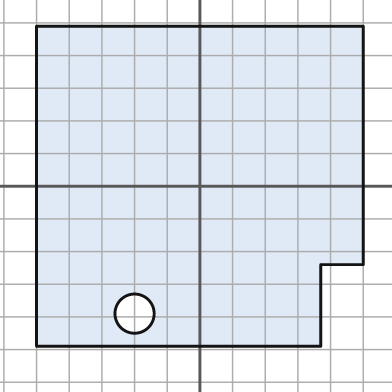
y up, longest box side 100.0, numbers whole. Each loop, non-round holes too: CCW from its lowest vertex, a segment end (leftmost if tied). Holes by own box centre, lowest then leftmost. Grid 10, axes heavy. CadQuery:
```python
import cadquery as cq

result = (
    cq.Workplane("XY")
    .moveTo(-50.0, -49.0)
    .lineTo(37.0, -49.0)
    .lineTo(37.0, -24.0)
    .lineTo(50.0, -24.0)
    .lineTo(50.0, 49.0)
    .lineTo(-50.0, 49.0)
    .close()
    .moveTo(-20.0, -39.0)
    .circle(6.0)
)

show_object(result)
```